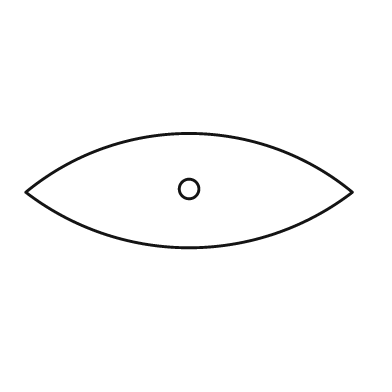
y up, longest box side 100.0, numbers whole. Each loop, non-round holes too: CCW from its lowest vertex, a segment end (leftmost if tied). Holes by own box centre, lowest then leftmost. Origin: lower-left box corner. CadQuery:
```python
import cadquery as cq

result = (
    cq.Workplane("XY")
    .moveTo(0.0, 17.0)
    .threePointArc((50.0, 0.0), (100.0, 17.0))
    .threePointArc((50.0, 35.0), (0.0, 17.0))
    .close()
    .moveTo(50.0, 18.0)
    .circle(3.0)
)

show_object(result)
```